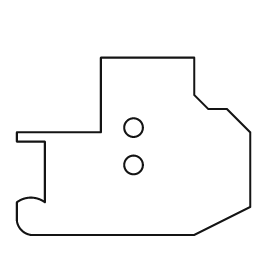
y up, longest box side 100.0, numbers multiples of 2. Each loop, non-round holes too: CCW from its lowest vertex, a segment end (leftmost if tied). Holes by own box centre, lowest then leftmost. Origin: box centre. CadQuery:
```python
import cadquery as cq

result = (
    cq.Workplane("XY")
    .moveTo(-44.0, -38.0)
    .lineTo(26.0, -38.0)
    .lineTo(50.0, -26.0)
    .lineTo(50.0, 6.0)
    .lineTo(40.0, 16.0)
    .lineTo(32.0, 16.0)
    .lineTo(26.0, 22.0)
    .lineTo(26.0, 38.0)
    .lineTo(-14.0, 38.0)
    .lineTo(-14.0, 6.0)
    .lineTo(-50.0, 6.0)
    .lineTo(-50.0, 2.0)
    .lineTo(-38.0, 2.0)
    .lineTo(-38.0, -24.0)
    .threePointArc((-44.0, -22.0), (-50.0, -24.0))
    .lineTo(-50.0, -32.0)
    .threePointArc((-48.0, -36.0), (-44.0, -38.0))
    .close()
    .moveTo(0.0, -8.0)
    .circle(4.0)
    .moveTo(0.0, 8.0)
    .circle(4.0)
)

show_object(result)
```